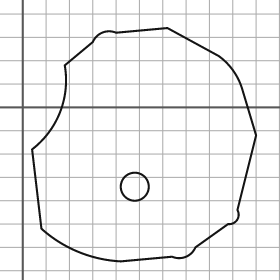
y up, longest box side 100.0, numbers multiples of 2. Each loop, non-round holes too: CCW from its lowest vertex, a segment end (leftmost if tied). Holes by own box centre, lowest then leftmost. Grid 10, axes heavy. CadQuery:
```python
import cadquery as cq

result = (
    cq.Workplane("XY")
    .moveTo(42.0, -66.0)
    .lineTo(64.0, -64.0)
    .threePointArc((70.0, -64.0), (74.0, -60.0))
    .lineTo(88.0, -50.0)
    .threePointArc((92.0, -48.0), (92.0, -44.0))
    .lineTo(100.0, -12.0)
    .lineTo(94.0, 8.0)
    .threePointArc((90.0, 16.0), (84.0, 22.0))
    .lineTo(62.0, 34.0)
    .lineTo(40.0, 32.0)
    .threePointArc((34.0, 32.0), (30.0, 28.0))
    .lineTo(18.0, 18.0)
    .threePointArc((16.0, -2.0), (4.0, -18.0))
    .lineTo(8.0, -52.0)
    .threePointArc((24.0, -62.0), (42.0, -66.0))
    .close()
    .moveTo(48.0, -34.0)
    .circle(6.0)
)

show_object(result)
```